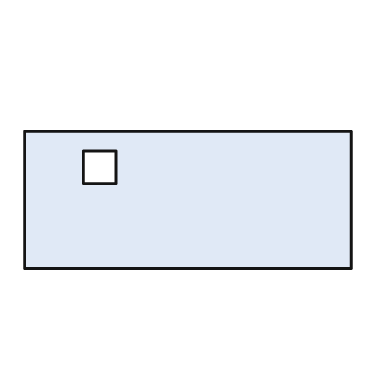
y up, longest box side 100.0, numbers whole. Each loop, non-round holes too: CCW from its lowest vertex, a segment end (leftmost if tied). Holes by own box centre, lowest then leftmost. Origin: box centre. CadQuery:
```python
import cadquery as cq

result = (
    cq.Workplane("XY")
    .moveTo(-50.0, -21.0)
    .lineTo(50.0, -21.0)
    .lineTo(50.0, 21.0)
    .lineTo(-50.0, 21.0)
    .close()
    .moveTo(-32.0, 5.0)
    .lineTo(-22.0, 5.0)
    .lineTo(-22.0, 15.0)
    .lineTo(-32.0, 15.0)
    .close()
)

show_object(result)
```